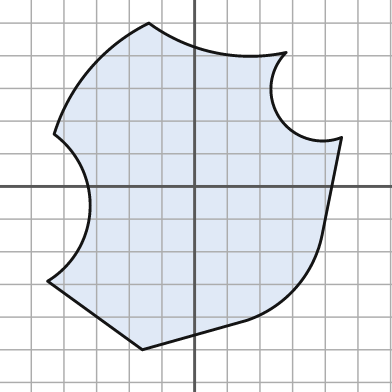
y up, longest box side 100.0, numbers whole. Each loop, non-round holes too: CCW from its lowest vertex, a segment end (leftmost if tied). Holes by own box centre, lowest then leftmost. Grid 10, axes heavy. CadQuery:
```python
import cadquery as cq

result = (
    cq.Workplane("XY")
    .moveTo(-16.0, -50.0)
    .lineTo(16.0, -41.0)
    .threePointArc((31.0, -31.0), (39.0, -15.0))
    .lineTo(45.0, 15.0)
    .threePointArc((26.0, 21.0), (28.0, 41.0))
    .threePointArc((6.0, 41.0), (-14.0, 50.0))
    .threePointArc((-32.0, 36.0), (-43.0, 16.0))
    .threePointArc((-32.0, -7.0), (-45.0, -29.0))
    .close()
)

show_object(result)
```